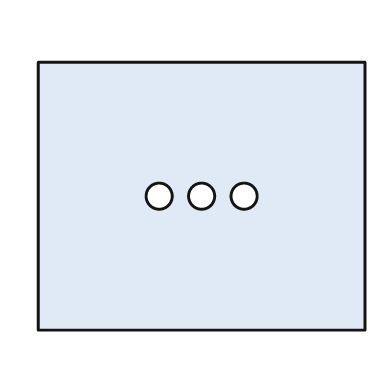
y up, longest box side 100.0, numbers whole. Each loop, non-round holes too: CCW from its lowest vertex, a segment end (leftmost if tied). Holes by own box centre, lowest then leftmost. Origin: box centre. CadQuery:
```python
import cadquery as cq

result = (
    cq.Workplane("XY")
    .moveTo(-50.0, -41.0)
    .lineTo(50.0, -41.0)
    .lineTo(50.0, 41.0)
    .lineTo(-50.0, 41.0)
    .close()
    .moveTo(-13.0, 0.0)
    .circle(4.0)
    .moveTo(0.0, 0.0)
    .circle(4.0)
    .moveTo(13.0, 0.0)
    .circle(4.0)
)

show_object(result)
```